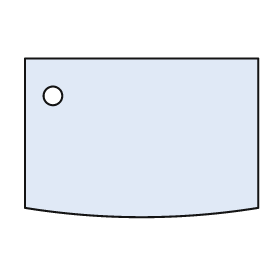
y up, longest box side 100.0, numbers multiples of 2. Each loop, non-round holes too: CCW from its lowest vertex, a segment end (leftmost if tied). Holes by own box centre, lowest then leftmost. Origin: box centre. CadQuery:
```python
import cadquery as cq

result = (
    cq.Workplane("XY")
    .moveTo(-50.0, -30.0)
    .threePointArc((0.0, -34.0), (50.0, -30.0))
    .lineTo(50.0, 34.0)
    .lineTo(-50.0, 34.0)
    .close()
    .moveTo(-38.0, 18.0)
    .circle(4.0)
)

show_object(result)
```